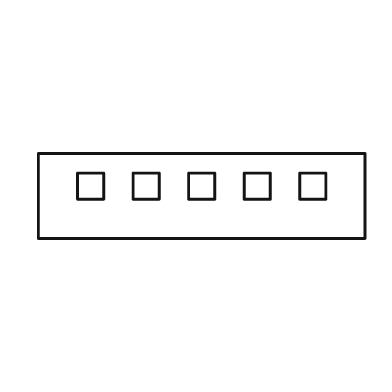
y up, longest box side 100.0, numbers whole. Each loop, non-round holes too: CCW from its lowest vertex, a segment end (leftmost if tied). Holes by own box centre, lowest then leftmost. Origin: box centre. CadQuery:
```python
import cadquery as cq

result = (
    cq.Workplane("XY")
    .moveTo(-50.0, -13.0)
    .lineTo(50.0, -13.0)
    .lineTo(50.0, 13.0)
    .lineTo(-50.0, 13.0)
    .close()
    .moveTo(-38.0, -1.0)
    .lineTo(-30.0, -1.0)
    .lineTo(-30.0, 7.0)
    .lineTo(-38.0, 7.0)
    .close()
    .moveTo(-21.0, -1.0)
    .lineTo(-13.0, -1.0)
    .lineTo(-13.0, 7.0)
    .lineTo(-21.0, 7.0)
    .close()
    .moveTo(-4.0, -1.0)
    .lineTo(4.0, -1.0)
    .lineTo(4.0, 7.0)
    .lineTo(-4.0, 7.0)
    .close()
    .moveTo(13.0, -1.0)
    .lineTo(21.0, -1.0)
    .lineTo(21.0, 7.0)
    .lineTo(13.0, 7.0)
    .close()
    .moveTo(30.0, -1.0)
    .lineTo(38.0, -1.0)
    .lineTo(38.0, 7.0)
    .lineTo(30.0, 7.0)
    .close()
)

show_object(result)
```